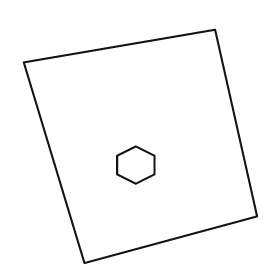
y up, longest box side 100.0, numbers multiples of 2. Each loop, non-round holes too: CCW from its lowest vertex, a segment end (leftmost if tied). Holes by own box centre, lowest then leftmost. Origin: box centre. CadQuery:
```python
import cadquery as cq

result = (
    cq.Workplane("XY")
    .moveTo(-24.0, -50.0)
    .lineTo(50.0, -30.0)
    .lineTo(32.0, 50.0)
    .lineTo(-50.0, 36.0)
    .close()
    .moveTo(-2.0, -16.0)
    .lineTo(6.0, -12.0)
    .lineTo(6.0, -4.0)
    .lineTo(-2.0, 0.0)
    .lineTo(-10.0, -4.0)
    .lineTo(-10.0, -12.0)
    .close()
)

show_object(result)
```